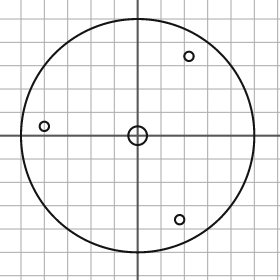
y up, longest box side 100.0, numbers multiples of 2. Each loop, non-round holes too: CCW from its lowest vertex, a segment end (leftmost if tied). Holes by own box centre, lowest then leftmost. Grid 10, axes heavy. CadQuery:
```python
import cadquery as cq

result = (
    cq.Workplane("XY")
    .moveTo(0.0, 0.0)
    .circle(50.0)
    .moveTo(18.0, -36.0)
    .circle(2.0)
    .moveTo(0.0, 0.0)
    .circle(4.0)
    .moveTo(-40.0, 4.0)
    .circle(2.0)
    .moveTo(22.0, 34.0)
    .circle(2.0)
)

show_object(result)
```